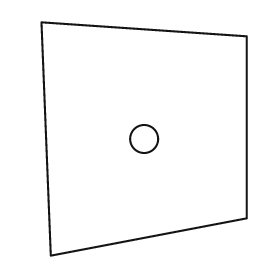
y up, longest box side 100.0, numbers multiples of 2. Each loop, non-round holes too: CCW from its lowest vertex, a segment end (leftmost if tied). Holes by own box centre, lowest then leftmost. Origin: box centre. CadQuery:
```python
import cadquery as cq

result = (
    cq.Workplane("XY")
    .moveTo(-40.0, -50.0)
    .lineTo(44.0, -34.0)
    .lineTo(44.0, 44.0)
    .lineTo(-44.0, 50.0)
    .close()
    .moveTo(0.0, 0.0)
    .circle(6.0)
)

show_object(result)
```